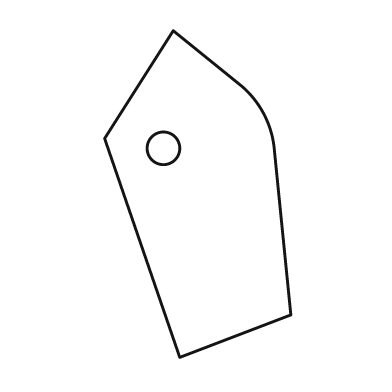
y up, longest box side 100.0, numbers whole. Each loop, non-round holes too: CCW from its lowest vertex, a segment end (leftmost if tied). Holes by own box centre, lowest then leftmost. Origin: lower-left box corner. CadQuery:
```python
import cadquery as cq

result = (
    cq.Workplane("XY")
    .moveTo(23.0, 0.0)
    .lineTo(57.0, 13.0)
    .lineTo(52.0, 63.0)
    .threePointArc((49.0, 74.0), (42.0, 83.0))
    .lineTo(21.0, 100.0)
    .lineTo(0.0, 67.0)
    .close()
    .moveTo(18.0, 64.0)
    .circle(5.0)
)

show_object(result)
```